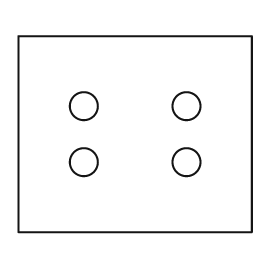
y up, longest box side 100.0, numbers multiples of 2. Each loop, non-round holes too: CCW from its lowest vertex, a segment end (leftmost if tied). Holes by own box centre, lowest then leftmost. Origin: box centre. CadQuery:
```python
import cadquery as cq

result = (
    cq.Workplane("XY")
    .moveTo(-50.0, -42.0)
    .lineTo(50.0, -42.0)
    .lineTo(50.0, 42.0)
    .lineTo(-50.0, 42.0)
    .close()
    .moveTo(-22.0, -12.0)
    .circle(6.0)
    .moveTo(22.0, -12.0)
    .circle(6.0)
    .moveTo(-22.0, 12.0)
    .circle(6.0)
    .moveTo(22.0, 12.0)
    .circle(6.0)
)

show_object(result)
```